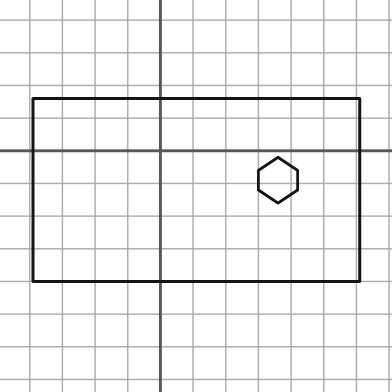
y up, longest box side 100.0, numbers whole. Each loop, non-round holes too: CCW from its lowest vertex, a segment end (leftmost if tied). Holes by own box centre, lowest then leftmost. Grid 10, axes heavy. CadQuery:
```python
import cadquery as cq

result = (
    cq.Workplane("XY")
    .moveTo(-39.0, -40.0)
    .lineTo(61.0, -40.0)
    .lineTo(61.0, 16.0)
    .lineTo(-39.0, 16.0)
    .close()
    .moveTo(36.0, -16.0)
    .lineTo(42.0, -12.0)
    .lineTo(42.0, -6.0)
    .lineTo(36.0, -2.0)
    .lineTo(30.0, -6.0)
    .lineTo(30.0, -12.0)
    .close()
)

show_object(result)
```